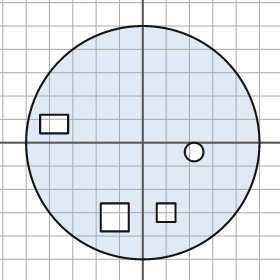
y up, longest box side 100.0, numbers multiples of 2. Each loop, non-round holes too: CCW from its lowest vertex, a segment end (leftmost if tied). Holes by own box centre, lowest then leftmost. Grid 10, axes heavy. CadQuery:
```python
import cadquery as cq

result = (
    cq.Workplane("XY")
    .moveTo(0.0, 0.0)
    .circle(50.0)
    .moveTo(-18.0, -38.0)
    .lineTo(-6.0, -38.0)
    .lineTo(-6.0, -26.0)
    .lineTo(-18.0, -26.0)
    .close()
    .moveTo(6.0, -34.0)
    .lineTo(14.0, -34.0)
    .lineTo(14.0, -26.0)
    .lineTo(6.0, -26.0)
    .close()
    .moveTo(22.0, -4.0)
    .circle(4.0)
    .moveTo(-44.0, 4.0)
    .lineTo(-32.0, 4.0)
    .lineTo(-32.0, 12.0)
    .lineTo(-44.0, 12.0)
    .close()
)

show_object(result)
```